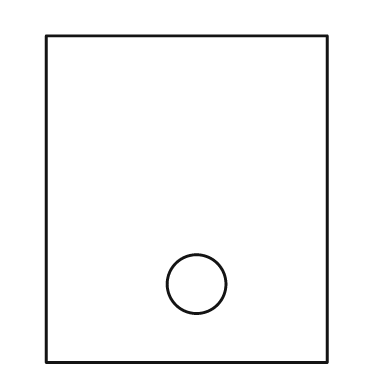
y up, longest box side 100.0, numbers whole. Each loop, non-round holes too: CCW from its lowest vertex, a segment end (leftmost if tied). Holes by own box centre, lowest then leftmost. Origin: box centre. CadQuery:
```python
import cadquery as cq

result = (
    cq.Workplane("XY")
    .moveTo(-43.0, -50.0)
    .lineTo(43.0, -50.0)
    .lineTo(43.0, 50.0)
    .lineTo(-43.0, 50.0)
    .close()
    .moveTo(3.0, -26.0)
    .circle(9.0)
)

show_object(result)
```